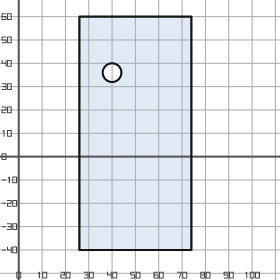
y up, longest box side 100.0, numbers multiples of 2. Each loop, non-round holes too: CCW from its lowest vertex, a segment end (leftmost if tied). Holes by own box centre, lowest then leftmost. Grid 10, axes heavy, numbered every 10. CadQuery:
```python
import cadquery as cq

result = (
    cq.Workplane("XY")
    .moveTo(26.0, -40.0)
    .lineTo(74.0, -40.0)
    .lineTo(74.0, 60.0)
    .lineTo(26.0, 60.0)
    .close()
    .moveTo(40.0, 36.0)
    .circle(4.0)
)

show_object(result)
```